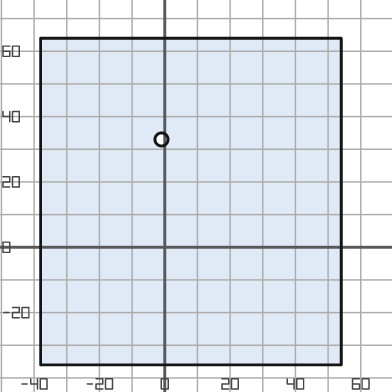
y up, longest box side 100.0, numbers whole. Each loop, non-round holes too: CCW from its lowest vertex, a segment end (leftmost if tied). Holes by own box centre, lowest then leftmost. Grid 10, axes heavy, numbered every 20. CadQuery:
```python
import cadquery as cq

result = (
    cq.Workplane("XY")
    .moveTo(-38.0, -36.0)
    .lineTo(54.0, -36.0)
    .lineTo(54.0, 64.0)
    .lineTo(-38.0, 64.0)
    .close()
    .moveTo(-1.0, 33.0)
    .circle(2.0)
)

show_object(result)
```